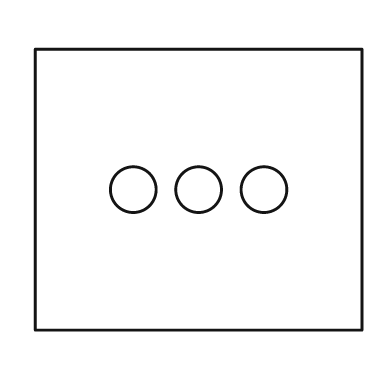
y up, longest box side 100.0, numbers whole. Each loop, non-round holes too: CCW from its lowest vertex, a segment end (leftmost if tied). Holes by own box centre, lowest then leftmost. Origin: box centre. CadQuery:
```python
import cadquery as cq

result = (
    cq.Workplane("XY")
    .moveTo(-50.0, -43.0)
    .lineTo(50.0, -43.0)
    .lineTo(50.0, 43.0)
    .lineTo(-50.0, 43.0)
    .close()
    .moveTo(-20.0, 0.0)
    .circle(7.0)
    .moveTo(0.0, 0.0)
    .circle(7.0)
    .moveTo(20.0, 0.0)
    .circle(7.0)
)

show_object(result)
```